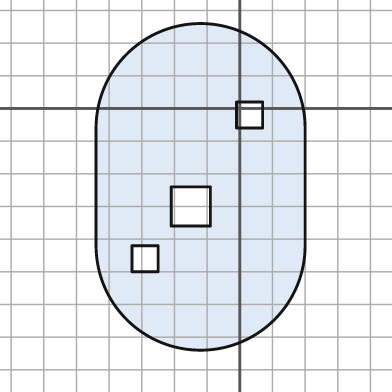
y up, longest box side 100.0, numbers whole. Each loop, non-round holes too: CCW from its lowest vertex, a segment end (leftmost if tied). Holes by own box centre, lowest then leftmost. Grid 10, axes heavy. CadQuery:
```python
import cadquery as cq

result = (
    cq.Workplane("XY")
    .moveTo(-44.0, -42.0)
    .threePointArc((-12.0, -74.0), (20.0, -42.0))
    .lineTo(20.0, -6.0)
    .threePointArc((-12.0, 26.0), (-44.0, -6.0))
    .close()
    .moveTo(-33.0, -50.0)
    .lineTo(-25.0, -50.0)
    .lineTo(-25.0, -42.0)
    .lineTo(-33.0, -42.0)
    .close()
    .moveTo(-21.0, -36.0)
    .lineTo(-9.0, -36.0)
    .lineTo(-9.0, -24.0)
    .lineTo(-21.0, -24.0)
    .close()
    .moveTo(-1.0, -6.0)
    .lineTo(7.0, -6.0)
    .lineTo(7.0, 2.0)
    .lineTo(-1.0, 2.0)
    .close()
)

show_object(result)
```